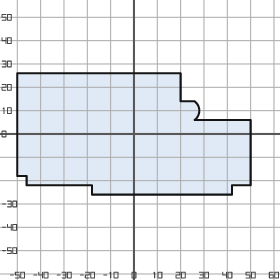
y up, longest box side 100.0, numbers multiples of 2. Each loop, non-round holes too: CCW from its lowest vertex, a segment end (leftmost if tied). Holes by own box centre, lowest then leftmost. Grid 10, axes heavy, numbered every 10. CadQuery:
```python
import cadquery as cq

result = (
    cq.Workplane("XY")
    .moveTo(-18.0, -26.0)
    .lineTo(42.0, -26.0)
    .lineTo(42.0, -22.0)
    .lineTo(50.0, -22.0)
    .lineTo(50.0, 6.0)
    .lineTo(26.0, 6.0)
    .threePointArc((28.0, 10.0), (26.0, 14.0))
    .lineTo(20.0, 14.0)
    .lineTo(20.0, 26.0)
    .lineTo(-50.0, 26.0)
    .lineTo(-50.0, -18.0)
    .lineTo(-46.0, -18.0)
    .lineTo(-46.0, -22.0)
    .lineTo(-18.0, -22.0)
    .close()
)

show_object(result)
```